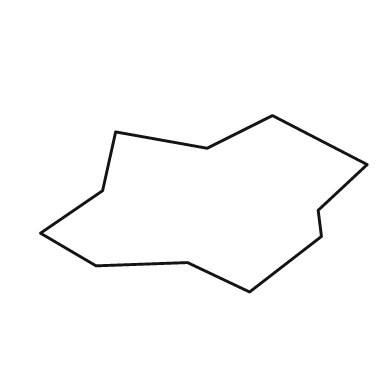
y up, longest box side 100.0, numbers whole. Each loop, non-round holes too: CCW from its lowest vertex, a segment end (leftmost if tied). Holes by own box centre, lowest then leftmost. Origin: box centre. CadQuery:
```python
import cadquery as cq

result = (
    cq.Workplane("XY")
    .moveTo(14.0, -27.0)
    .lineTo(36.0, -10.0)
    .lineTo(35.0, -2.0)
    .lineTo(50.0, 12.0)
    .lineTo(21.0, 27.0)
    .lineTo(1.0, 17.0)
    .lineTo(-27.0, 22.0)
    .lineTo(-31.0, 4.0)
    .lineTo(-50.0, -9.0)
    .lineTo(-33.0, -19.0)
    .lineTo(-5.0, -18.0)
    .close()
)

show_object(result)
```